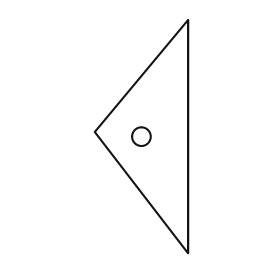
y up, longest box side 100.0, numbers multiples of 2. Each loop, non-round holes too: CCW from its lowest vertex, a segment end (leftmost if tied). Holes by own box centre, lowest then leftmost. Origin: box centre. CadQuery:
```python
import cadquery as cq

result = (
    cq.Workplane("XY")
    .moveTo(20.0, -50.0)
    .lineTo(20.0, 50.0)
    .lineTo(-20.0, 2.0)
    .close()
    .moveTo(0.0, 0.0)
    .circle(4.0)
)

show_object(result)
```